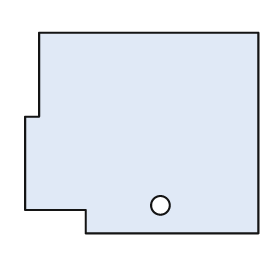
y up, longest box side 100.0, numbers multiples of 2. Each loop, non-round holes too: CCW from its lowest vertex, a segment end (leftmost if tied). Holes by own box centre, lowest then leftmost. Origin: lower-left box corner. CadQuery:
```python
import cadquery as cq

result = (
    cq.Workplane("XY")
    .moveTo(26.0, 0.0)
    .lineTo(100.0, 0.0)
    .lineTo(100.0, 86.0)
    .lineTo(6.0, 86.0)
    .lineTo(6.0, 50.0)
    .lineTo(0.0, 50.0)
    .lineTo(0.0, 10.0)
    .lineTo(26.0, 10.0)
    .close()
    .moveTo(58.0, 12.0)
    .circle(4.0)
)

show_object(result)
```